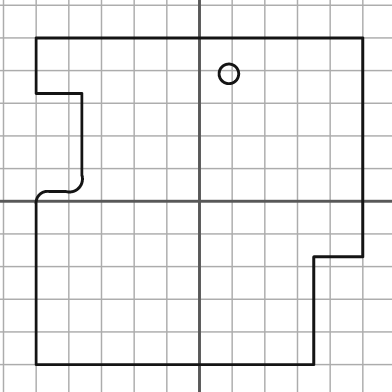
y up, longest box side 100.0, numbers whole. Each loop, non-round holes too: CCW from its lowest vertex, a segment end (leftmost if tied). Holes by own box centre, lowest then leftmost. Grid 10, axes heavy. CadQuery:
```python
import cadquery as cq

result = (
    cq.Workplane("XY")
    .moveTo(-50.0, -50.0)
    .lineTo(35.0, -50.0)
    .lineTo(35.0, -17.0)
    .lineTo(50.0, -17.0)
    .lineTo(50.0, 50.0)
    .lineTo(-50.0, 50.0)
    .lineTo(-50.0, 33.0)
    .lineTo(-36.0, 33.0)
    .lineTo(-36.0, 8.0)
    .threePointArc((-37.0, 4.0), (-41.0, 3.0))
    .lineTo(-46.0, 3.0)
    .threePointArc((-49.0, 2.0), (-50.0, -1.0))
    .close()
    .moveTo(9.0, 39.0)
    .circle(3.0)
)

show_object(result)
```